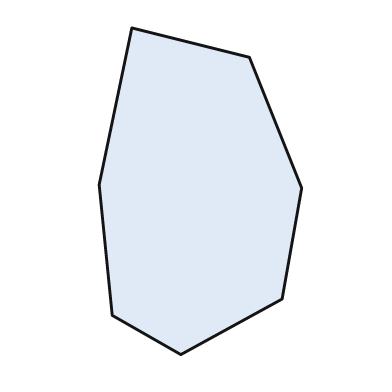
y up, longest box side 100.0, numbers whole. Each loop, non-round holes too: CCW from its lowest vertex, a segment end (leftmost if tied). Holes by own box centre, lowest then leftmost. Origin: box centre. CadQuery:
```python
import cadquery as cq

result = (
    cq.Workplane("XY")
    .moveTo(-6.0, -50.0)
    .lineTo(25.0, -33.0)
    .lineTo(31.0, 1.0)
    .lineTo(15.0, 41.0)
    .lineTo(-21.0, 50.0)
    .lineTo(-31.0, 2.0)
    .lineTo(-27.0, -38.0)
    .close()
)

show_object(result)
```